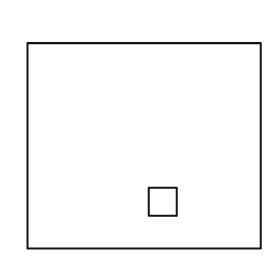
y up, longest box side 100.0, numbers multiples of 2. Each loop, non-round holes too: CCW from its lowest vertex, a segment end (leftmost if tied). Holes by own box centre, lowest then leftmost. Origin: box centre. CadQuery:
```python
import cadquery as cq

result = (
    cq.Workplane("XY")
    .moveTo(-50.0, -44.0)
    .lineTo(50.0, -44.0)
    .lineTo(50.0, 44.0)
    .lineTo(-50.0, 44.0)
    .close()
    .moveTo(2.0, -30.0)
    .lineTo(14.0, -30.0)
    .lineTo(14.0, -18.0)
    .lineTo(2.0, -18.0)
    .close()
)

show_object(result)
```